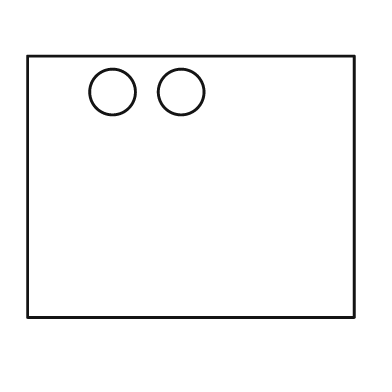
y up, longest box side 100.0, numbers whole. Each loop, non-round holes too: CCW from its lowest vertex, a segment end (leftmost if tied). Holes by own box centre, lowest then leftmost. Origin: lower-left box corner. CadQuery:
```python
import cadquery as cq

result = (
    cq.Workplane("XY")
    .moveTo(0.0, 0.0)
    .lineTo(100.0, 0.0)
    .lineTo(100.0, 80.0)
    .lineTo(0.0, 80.0)
    .close()
    .moveTo(26.0, 69.0)
    .circle(7.0)
    .moveTo(47.0, 69.0)
    .circle(7.0)
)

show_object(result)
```